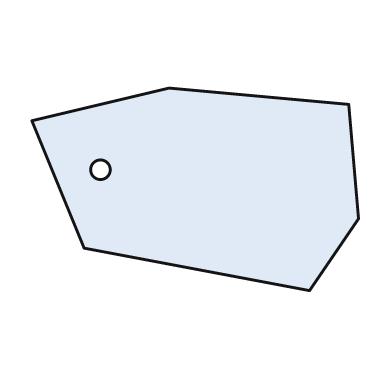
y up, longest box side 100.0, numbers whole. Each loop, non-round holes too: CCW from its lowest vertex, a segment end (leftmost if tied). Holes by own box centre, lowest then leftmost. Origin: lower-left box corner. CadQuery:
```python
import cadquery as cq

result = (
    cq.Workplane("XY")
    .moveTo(85.0, 0.0)
    .lineTo(100.0, 22.0)
    .lineTo(97.0, 57.0)
    .lineTo(42.0, 62.0)
    .lineTo(0.0, 52.0)
    .lineTo(16.0, 13.0)
    .close()
    .moveTo(21.0, 37.0)
    .circle(3.0)
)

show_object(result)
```